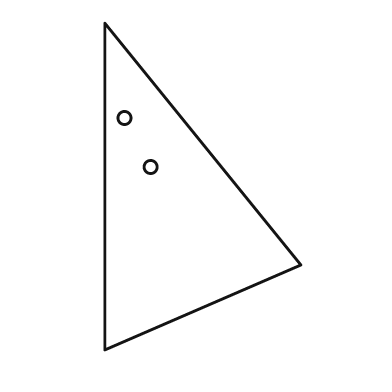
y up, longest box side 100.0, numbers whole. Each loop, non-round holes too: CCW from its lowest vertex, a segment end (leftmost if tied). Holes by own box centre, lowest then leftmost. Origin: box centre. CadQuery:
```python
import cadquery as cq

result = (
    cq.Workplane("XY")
    .moveTo(-30.0, -50.0)
    .lineTo(30.0, -24.0)
    .lineTo(-30.0, 50.0)
    .close()
    .moveTo(-16.0, 6.0)
    .circle(2.0)
    .moveTo(-24.0, 21.0)
    .circle(2.0)
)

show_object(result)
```